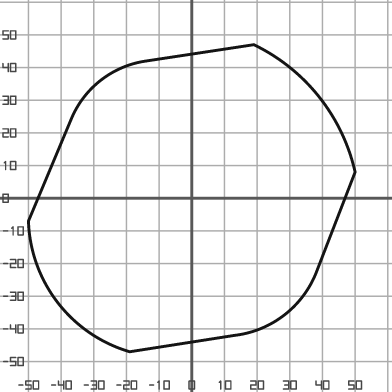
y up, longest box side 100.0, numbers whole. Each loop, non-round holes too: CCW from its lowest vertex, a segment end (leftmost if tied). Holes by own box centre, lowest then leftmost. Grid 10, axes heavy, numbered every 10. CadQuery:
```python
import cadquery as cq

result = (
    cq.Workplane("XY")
    .moveTo(-19.0, -47.0)
    .lineTo(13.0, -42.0)
    .threePointArc((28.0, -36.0), (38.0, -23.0))
    .lineTo(50.0, 8.0)
    .threePointArc((39.0, 31.0), (19.0, 47.0))
    .lineTo(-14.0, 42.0)
    .threePointArc((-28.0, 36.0), (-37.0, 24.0))
    .lineTo(-50.0, -7.0)
    .threePointArc((-41.0, -32.0), (-19.0, -47.0))
    .close()
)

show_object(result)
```